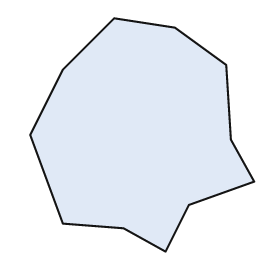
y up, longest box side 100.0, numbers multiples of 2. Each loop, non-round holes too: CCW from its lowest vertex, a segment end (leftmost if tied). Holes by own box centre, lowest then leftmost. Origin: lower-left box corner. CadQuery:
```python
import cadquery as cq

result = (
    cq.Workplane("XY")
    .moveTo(58.0, 0.0)
    .lineTo(68.0, 20.0)
    .lineTo(96.0, 30.0)
    .lineTo(86.0, 48.0)
    .lineTo(84.0, 80.0)
    .lineTo(62.0, 96.0)
    .lineTo(36.0, 100.0)
    .lineTo(14.0, 78.0)
    .lineTo(0.0, 50.0)
    .lineTo(14.0, 12.0)
    .lineTo(40.0, 10.0)
    .close()
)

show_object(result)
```